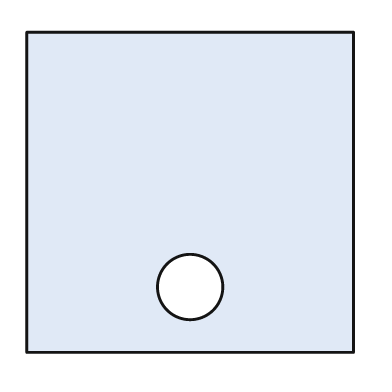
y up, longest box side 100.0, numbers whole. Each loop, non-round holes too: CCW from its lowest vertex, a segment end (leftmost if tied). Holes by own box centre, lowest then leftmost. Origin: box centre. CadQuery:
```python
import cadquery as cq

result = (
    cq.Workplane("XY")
    .moveTo(-50.0, -49.0)
    .lineTo(50.0, -49.0)
    .lineTo(50.0, 49.0)
    .lineTo(-50.0, 49.0)
    .close()
    .moveTo(0.0, -29.0)
    .circle(10.0)
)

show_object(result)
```